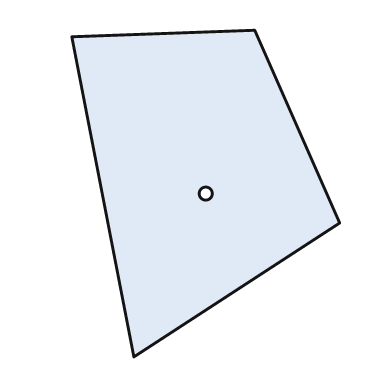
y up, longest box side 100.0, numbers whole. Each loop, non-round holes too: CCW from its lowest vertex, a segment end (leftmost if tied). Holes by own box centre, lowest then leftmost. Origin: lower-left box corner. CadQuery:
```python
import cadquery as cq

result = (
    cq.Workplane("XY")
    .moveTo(19.0, 0.0)
    .lineTo(82.0, 41.0)
    .lineTo(56.0, 100.0)
    .lineTo(0.0, 98.0)
    .close()
    .moveTo(41.0, 50.0)
    .circle(2.0)
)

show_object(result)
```